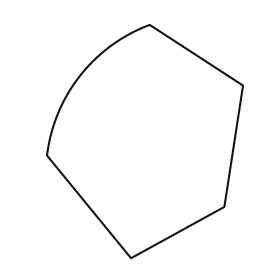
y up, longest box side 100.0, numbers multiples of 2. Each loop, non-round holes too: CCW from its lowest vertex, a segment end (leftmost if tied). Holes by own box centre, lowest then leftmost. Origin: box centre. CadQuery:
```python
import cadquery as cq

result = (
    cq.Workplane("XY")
    .moveTo(-6.0, -50.0)
    .lineTo(34.0, -28.0)
    .lineTo(42.0, 24.0)
    .lineTo(2.0, 50.0)
    .threePointArc((-28.0, 28.0), (-42.0, -6.0))
    .close()
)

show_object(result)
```